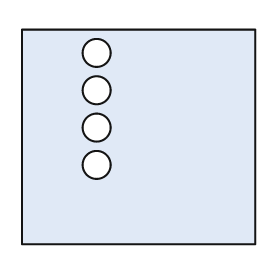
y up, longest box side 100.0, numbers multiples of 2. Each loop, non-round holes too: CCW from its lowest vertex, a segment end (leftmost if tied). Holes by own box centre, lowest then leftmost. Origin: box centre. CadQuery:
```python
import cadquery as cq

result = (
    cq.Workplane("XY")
    .moveTo(-50.0, -46.0)
    .lineTo(50.0, -46.0)
    .lineTo(50.0, 46.0)
    .lineTo(-50.0, 46.0)
    .close()
    .moveTo(-18.0, -12.0)
    .circle(6.0)
    .moveTo(-18.0, 4.0)
    .circle(6.0)
    .moveTo(-18.0, 20.0)
    .circle(6.0)
    .moveTo(-18.0, 36.0)
    .circle(6.0)
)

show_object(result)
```